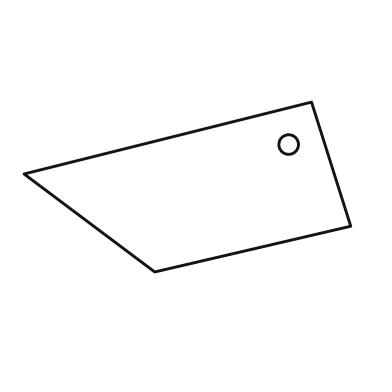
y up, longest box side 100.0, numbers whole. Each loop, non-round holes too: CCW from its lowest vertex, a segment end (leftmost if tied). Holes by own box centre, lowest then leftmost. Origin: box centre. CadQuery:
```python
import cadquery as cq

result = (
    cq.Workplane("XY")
    .moveTo(-10.0, -26.0)
    .lineTo(50.0, -12.0)
    .lineTo(38.0, 26.0)
    .lineTo(-50.0, 4.0)
    .close()
    .moveTo(31.0, 13.0)
    .circle(3.0)
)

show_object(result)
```